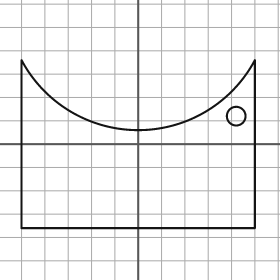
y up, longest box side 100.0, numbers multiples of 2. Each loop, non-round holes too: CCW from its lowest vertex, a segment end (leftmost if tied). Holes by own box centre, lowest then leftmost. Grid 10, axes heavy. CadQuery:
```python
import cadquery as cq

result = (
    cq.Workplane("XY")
    .moveTo(-50.0, -36.0)
    .lineTo(50.0, -36.0)
    .lineTo(50.0, 36.0)
    .threePointArc((0.0, 6.0), (-50.0, 36.0))
    .close()
    .moveTo(42.0, 12.0)
    .circle(4.0)
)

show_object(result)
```